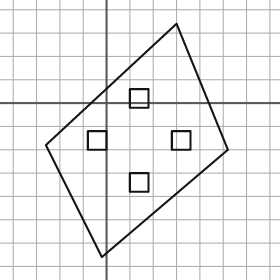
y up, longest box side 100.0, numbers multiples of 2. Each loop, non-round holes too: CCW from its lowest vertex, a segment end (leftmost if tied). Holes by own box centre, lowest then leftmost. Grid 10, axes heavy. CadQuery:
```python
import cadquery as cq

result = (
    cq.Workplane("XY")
    .moveTo(-2.0, -66.0)
    .lineTo(52.0, -20.0)
    .lineTo(30.0, 34.0)
    .lineTo(-26.0, -18.0)
    .close()
    .moveTo(10.0, -38.0)
    .lineTo(18.0, -38.0)
    .lineTo(18.0, -30.0)
    .lineTo(10.0, -30.0)
    .close()
    .moveTo(-8.0, -20.0)
    .lineTo(0.0, -20.0)
    .lineTo(0.0, -12.0)
    .lineTo(-8.0, -12.0)
    .close()
    .moveTo(28.0, -20.0)
    .lineTo(36.0, -20.0)
    .lineTo(36.0, -12.0)
    .lineTo(28.0, -12.0)
    .close()
    .moveTo(10.0, -2.0)
    .lineTo(18.0, -2.0)
    .lineTo(18.0, 6.0)
    .lineTo(10.0, 6.0)
    .close()
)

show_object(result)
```